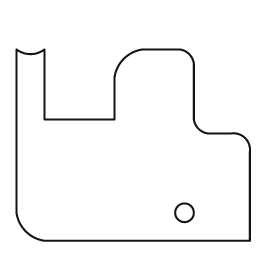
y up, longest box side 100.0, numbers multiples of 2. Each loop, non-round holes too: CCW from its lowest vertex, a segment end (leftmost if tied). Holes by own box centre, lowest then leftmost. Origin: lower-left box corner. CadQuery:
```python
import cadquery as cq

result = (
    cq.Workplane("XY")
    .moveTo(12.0, 0.0)
    .lineTo(100.0, 0.0)
    .lineTo(100.0, 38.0)
    .threePointArc((98.0, 44.0), (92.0, 46.0))
    .lineTo(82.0, 46.0)
    .threePointArc((78.0, 48.0), (76.0, 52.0))
    .lineTo(76.0, 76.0)
    .threePointArc((74.0, 80.0), (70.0, 82.0))
    .lineTo(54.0, 82.0)
    .threePointArc((46.0, 78.0), (42.0, 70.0))
    .lineTo(42.0, 52.0)
    .lineTo(12.0, 52.0)
    .lineTo(12.0, 82.0)
    .threePointArc((6.0, 80.0), (0.0, 82.0))
    .lineTo(0.0, 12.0)
    .threePointArc((4.0, 4.0), (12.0, 0.0))
    .close()
    .moveTo(72.0, 12.0)
    .circle(4.0)
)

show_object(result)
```